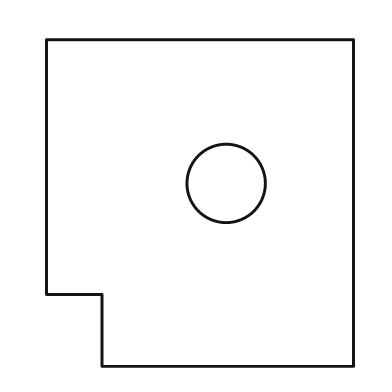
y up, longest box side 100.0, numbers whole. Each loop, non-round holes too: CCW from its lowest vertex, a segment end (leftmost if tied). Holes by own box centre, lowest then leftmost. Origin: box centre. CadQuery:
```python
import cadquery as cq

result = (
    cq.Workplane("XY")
    .moveTo(-30.0, -50.0)
    .lineTo(47.0, -50.0)
    .lineTo(47.0, 50.0)
    .lineTo(-47.0, 50.0)
    .lineTo(-47.0, -28.0)
    .lineTo(-30.0, -28.0)
    .close()
    .moveTo(8.0, 6.0)
    .circle(12.0)
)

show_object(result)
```